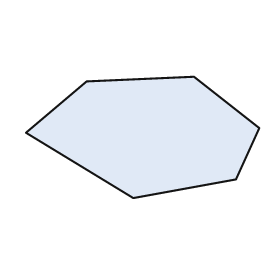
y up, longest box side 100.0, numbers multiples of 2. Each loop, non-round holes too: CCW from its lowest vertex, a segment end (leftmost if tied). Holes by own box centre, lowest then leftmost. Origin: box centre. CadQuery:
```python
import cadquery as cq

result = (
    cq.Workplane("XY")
    .moveTo(-4.0, -26.0)
    .lineTo(40.0, -18.0)
    .lineTo(50.0, 4.0)
    .lineTo(22.0, 26.0)
    .lineTo(-24.0, 24.0)
    .lineTo(-50.0, 2.0)
    .close()
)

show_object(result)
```